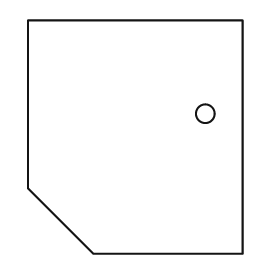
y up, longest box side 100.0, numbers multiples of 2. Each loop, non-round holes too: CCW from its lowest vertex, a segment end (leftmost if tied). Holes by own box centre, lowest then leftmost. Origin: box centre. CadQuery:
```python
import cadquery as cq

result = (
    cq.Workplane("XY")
    .moveTo(-18.0, -50.0)
    .lineTo(46.0, -50.0)
    .lineTo(46.0, 50.0)
    .lineTo(-46.0, 50.0)
    .lineTo(-46.0, -22.0)
    .close()
    .moveTo(30.0, 10.0)
    .circle(4.0)
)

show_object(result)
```